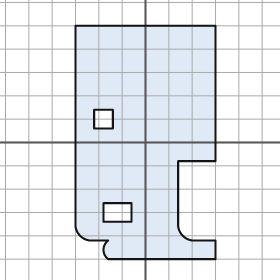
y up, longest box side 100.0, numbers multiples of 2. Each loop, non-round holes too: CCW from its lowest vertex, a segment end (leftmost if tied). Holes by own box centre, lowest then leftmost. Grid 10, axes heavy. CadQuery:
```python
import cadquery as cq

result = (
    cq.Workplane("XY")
    .moveTo(-16.0, -50.0)
    .lineTo(30.0, -50.0)
    .lineTo(30.0, -42.0)
    .lineTo(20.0, -42.0)
    .threePointArc((16.0, -40.0), (14.0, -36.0))
    .lineTo(14.0, -8.0)
    .lineTo(30.0, -8.0)
    .lineTo(30.0, 50.0)
    .lineTo(-30.0, 50.0)
    .lineTo(-30.0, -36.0)
    .threePointArc((-28.0, -40.0), (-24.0, -42.0))
    .lineTo(-16.0, -42.0)
    .threePointArc((-18.0, -46.0), (-16.0, -50.0))
    .close()
    .moveTo(-18.0, -34.0)
    .lineTo(-6.0, -34.0)
    .lineTo(-6.0, -26.0)
    .lineTo(-18.0, -26.0)
    .close()
    .moveTo(-22.0, 6.0)
    .lineTo(-14.0, 6.0)
    .lineTo(-14.0, 14.0)
    .lineTo(-22.0, 14.0)
    .close()
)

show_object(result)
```